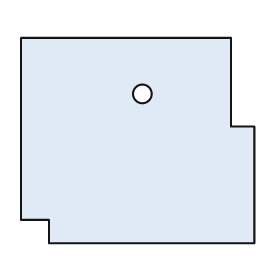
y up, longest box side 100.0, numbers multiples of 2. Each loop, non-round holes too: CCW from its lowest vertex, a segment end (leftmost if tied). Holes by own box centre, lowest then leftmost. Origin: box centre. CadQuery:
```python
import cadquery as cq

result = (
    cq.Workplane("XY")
    .moveTo(-38.0, -44.0)
    .lineTo(50.0, -44.0)
    .lineTo(50.0, 6.0)
    .lineTo(40.0, 6.0)
    .lineTo(40.0, 44.0)
    .lineTo(-50.0, 44.0)
    .lineTo(-50.0, -34.0)
    .lineTo(-38.0, -34.0)
    .close()
    .moveTo(2.0, 20.0)
    .circle(4.0)
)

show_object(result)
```